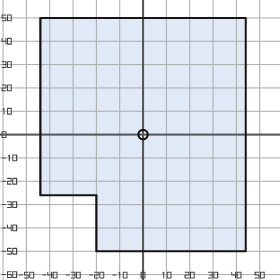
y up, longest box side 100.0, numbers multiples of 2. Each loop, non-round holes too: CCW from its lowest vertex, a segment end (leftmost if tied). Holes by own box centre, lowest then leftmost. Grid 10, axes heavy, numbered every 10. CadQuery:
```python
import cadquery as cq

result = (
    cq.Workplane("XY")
    .moveTo(-20.0, -50.0)
    .lineTo(44.0, -50.0)
    .lineTo(44.0, 50.0)
    .lineTo(-44.0, 50.0)
    .lineTo(-44.0, -26.0)
    .lineTo(-20.0, -26.0)
    .close()
    .moveTo(0.0, 0.0)
    .circle(2.0)
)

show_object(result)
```